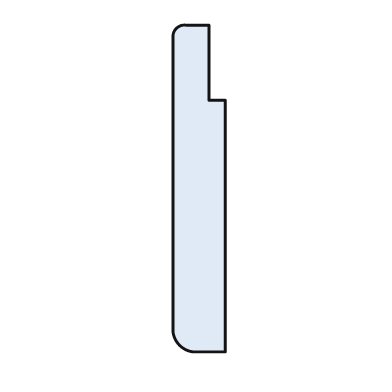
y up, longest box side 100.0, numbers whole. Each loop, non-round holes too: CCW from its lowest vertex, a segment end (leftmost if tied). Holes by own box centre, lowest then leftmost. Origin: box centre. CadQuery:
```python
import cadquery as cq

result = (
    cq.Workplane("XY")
    .moveTo(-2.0, -50.0)
    .lineTo(8.0, -50.0)
    .lineTo(8.0, 27.0)
    .lineTo(3.0, 27.0)
    .lineTo(3.0, 50.0)
    .lineTo(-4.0, 50.0)
    .threePointArc((-7.0, 49.0), (-8.0, 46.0))
    .lineTo(-8.0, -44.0)
    .threePointArc((-6.0, -48.0), (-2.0, -50.0))
    .close()
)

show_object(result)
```